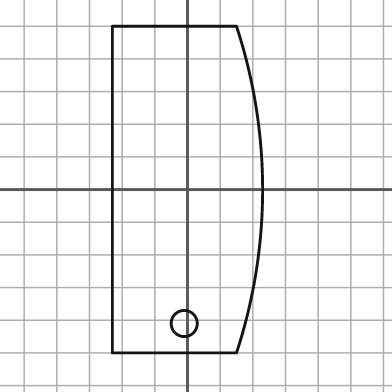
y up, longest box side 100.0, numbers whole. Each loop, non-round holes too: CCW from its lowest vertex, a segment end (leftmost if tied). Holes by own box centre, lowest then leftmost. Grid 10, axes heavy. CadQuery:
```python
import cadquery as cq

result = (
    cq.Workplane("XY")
    .moveTo(-23.0, -50.0)
    .lineTo(15.0, -50.0)
    .threePointArc((23.0, 0.0), (15.0, 50.0))
    .lineTo(-23.0, 50.0)
    .close()
    .moveTo(-1.0, -41.0)
    .circle(4.0)
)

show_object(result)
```